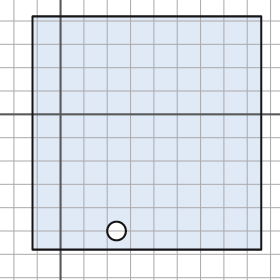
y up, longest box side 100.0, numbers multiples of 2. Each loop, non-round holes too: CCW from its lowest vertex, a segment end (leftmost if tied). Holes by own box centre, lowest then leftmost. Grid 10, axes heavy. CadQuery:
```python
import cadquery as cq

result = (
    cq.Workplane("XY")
    .moveTo(-12.0, -58.0)
    .lineTo(86.0, -58.0)
    .lineTo(86.0, 42.0)
    .lineTo(-12.0, 42.0)
    .close()
    .moveTo(24.0, -50.0)
    .circle(4.0)
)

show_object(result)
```